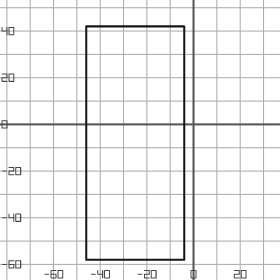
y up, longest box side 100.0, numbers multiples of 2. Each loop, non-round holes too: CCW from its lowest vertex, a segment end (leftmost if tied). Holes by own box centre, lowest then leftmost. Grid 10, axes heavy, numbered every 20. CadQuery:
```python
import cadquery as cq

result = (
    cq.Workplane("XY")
    .moveTo(-46.0, -58.0)
    .lineTo(-4.0, -58.0)
    .lineTo(-4.0, 42.0)
    .lineTo(-46.0, 42.0)
    .close()
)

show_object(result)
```